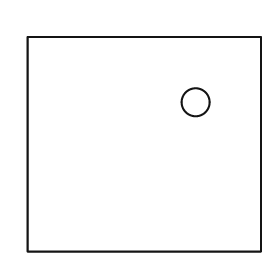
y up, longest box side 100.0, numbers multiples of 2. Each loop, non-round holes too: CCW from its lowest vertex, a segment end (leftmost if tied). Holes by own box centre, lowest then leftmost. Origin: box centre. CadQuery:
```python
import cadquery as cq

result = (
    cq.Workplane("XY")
    .moveTo(-50.0, -46.0)
    .lineTo(50.0, -46.0)
    .lineTo(50.0, 46.0)
    .lineTo(-50.0, 46.0)
    .close()
    .moveTo(22.0, 18.0)
    .circle(6.0)
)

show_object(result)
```